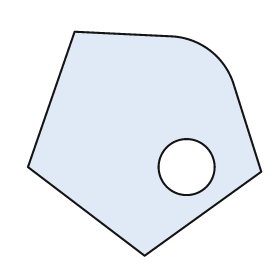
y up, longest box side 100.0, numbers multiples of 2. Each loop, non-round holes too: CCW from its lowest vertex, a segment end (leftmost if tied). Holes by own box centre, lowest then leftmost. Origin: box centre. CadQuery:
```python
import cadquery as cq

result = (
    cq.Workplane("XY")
    .moveTo(0.0, -48.0)
    .lineTo(50.0, -12.0)
    .lineTo(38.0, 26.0)
    .threePointArc((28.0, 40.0), (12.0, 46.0))
    .lineTo(-30.0, 48.0)
    .lineTo(-50.0, -10.0)
    .close()
    .moveTo(18.0, -10.0)
    .circle(12.0)
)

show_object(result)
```